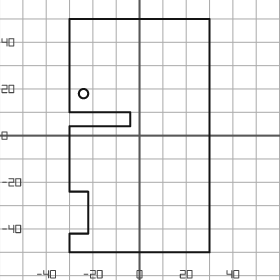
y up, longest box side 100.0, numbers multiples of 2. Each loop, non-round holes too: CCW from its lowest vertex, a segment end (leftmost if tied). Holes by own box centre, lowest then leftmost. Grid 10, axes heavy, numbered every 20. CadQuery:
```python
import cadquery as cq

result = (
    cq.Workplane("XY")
    .moveTo(-30.0, -50.0)
    .lineTo(30.0, -50.0)
    .lineTo(30.0, 50.0)
    .lineTo(-30.0, 50.0)
    .lineTo(-30.0, 10.0)
    .lineTo(-4.0, 10.0)
    .lineTo(-4.0, 4.0)
    .lineTo(-30.0, 4.0)
    .lineTo(-30.0, -24.0)
    .lineTo(-22.0, -24.0)
    .lineTo(-22.0, -42.0)
    .lineTo(-30.0, -42.0)
    .close()
    .moveTo(-24.0, 18.0)
    .circle(2.0)
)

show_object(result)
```